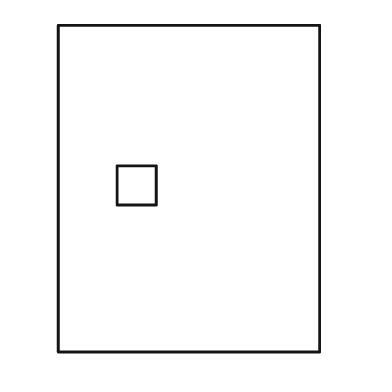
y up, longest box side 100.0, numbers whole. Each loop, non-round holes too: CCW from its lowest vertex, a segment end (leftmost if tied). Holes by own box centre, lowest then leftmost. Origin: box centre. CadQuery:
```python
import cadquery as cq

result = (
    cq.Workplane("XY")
    .moveTo(-40.0, -50.0)
    .lineTo(40.0, -50.0)
    .lineTo(40.0, 50.0)
    .lineTo(-40.0, 50.0)
    .close()
    .moveTo(-22.0, -5.0)
    .lineTo(-10.0, -5.0)
    .lineTo(-10.0, 7.0)
    .lineTo(-22.0, 7.0)
    .close()
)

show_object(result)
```